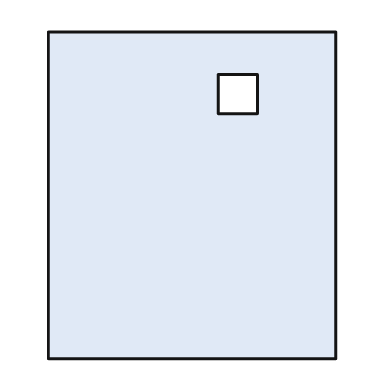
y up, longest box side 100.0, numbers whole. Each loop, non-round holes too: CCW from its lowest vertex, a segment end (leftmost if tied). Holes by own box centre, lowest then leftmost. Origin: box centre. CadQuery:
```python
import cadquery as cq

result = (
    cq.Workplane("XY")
    .moveTo(-44.0, -50.0)
    .lineTo(44.0, -50.0)
    .lineTo(44.0, 50.0)
    .lineTo(-44.0, 50.0)
    .close()
    .moveTo(8.0, 25.0)
    .lineTo(20.0, 25.0)
    .lineTo(20.0, 37.0)
    .lineTo(8.0, 37.0)
    .close()
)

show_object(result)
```